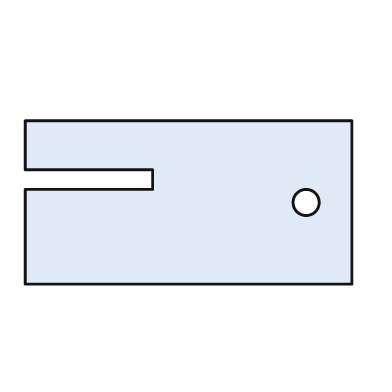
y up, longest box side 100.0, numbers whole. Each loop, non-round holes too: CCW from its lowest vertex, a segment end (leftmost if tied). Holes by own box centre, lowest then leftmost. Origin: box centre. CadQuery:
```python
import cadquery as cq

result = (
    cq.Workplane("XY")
    .moveTo(-50.0, -25.0)
    .lineTo(50.0, -25.0)
    .lineTo(50.0, 25.0)
    .lineTo(-50.0, 25.0)
    .lineTo(-50.0, 10.0)
    .lineTo(-11.0, 10.0)
    .lineTo(-11.0, 4.0)
    .lineTo(-50.0, 4.0)
    .close()
    .moveTo(36.0, 0.0)
    .circle(4.0)
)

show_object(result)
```